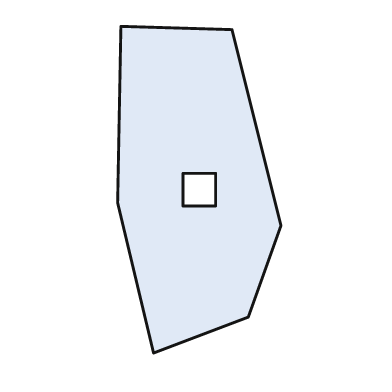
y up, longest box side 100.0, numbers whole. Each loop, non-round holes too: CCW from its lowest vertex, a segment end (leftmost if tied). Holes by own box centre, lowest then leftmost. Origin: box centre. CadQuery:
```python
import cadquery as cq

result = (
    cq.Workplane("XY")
    .moveTo(-14.0, -50.0)
    .lineTo(15.0, -39.0)
    .lineTo(25.0, -11.0)
    .lineTo(10.0, 49.0)
    .lineTo(-24.0, 50.0)
    .lineTo(-25.0, -4.0)
    .close()
    .moveTo(-5.0, -5.0)
    .lineTo(5.0, -5.0)
    .lineTo(5.0, 5.0)
    .lineTo(-5.0, 5.0)
    .close()
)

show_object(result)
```